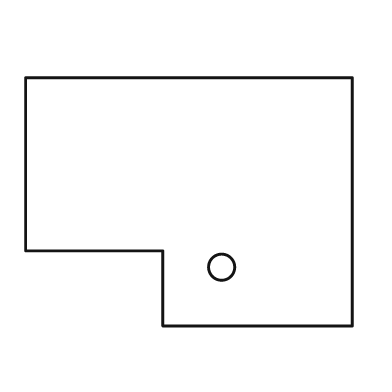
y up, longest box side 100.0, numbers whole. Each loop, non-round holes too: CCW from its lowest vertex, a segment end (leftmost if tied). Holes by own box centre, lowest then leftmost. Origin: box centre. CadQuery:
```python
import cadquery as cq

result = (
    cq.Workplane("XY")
    .moveTo(-8.0, -38.0)
    .lineTo(50.0, -38.0)
    .lineTo(50.0, 38.0)
    .lineTo(-50.0, 38.0)
    .lineTo(-50.0, -15.0)
    .lineTo(-8.0, -15.0)
    .close()
    .moveTo(10.0, -20.0)
    .circle(4.0)
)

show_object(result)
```